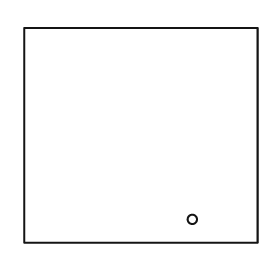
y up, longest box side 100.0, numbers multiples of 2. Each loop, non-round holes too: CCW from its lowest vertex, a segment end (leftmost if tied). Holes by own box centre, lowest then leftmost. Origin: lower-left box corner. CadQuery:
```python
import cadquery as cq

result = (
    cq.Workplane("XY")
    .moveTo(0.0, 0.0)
    .lineTo(100.0, 0.0)
    .lineTo(100.0, 92.0)
    .lineTo(0.0, 92.0)
    .close()
    .moveTo(72.0, 10.0)
    .circle(2.0)
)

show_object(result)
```